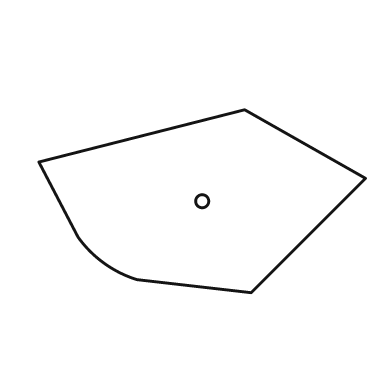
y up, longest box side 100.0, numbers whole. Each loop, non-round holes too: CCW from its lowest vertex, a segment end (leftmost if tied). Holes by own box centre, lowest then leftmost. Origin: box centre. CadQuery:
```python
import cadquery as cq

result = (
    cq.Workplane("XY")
    .moveTo(15.0, -28.0)
    .lineTo(50.0, 7.0)
    .lineTo(13.0, 28.0)
    .lineTo(-50.0, 12.0)
    .lineTo(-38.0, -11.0)
    .threePointArc((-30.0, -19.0), (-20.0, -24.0))
    .close()
    .moveTo(0.0, 0.0)
    .circle(2.0)
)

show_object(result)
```